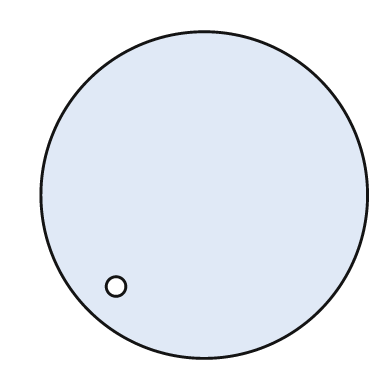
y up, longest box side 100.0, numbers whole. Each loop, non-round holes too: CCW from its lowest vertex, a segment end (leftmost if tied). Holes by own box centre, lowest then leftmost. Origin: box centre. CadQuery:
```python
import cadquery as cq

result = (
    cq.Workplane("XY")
    .moveTo(0.0, 0.0)
    .circle(50.0)
    .moveTo(-27.0, -28.0)
    .circle(3.0)
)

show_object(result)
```